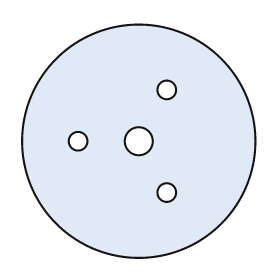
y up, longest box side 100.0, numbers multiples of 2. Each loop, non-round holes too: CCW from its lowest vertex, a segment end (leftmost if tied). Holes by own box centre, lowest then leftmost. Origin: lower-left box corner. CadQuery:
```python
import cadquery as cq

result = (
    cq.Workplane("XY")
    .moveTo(50.0, 50.0)
    .circle(50.0)
    .moveTo(62.0, 28.0)
    .circle(4.0)
    .moveTo(24.0, 50.0)
    .circle(4.0)
    .moveTo(50.0, 50.0)
    .circle(6.0)
    .moveTo(62.0, 72.0)
    .circle(4.0)
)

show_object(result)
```